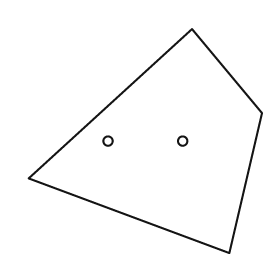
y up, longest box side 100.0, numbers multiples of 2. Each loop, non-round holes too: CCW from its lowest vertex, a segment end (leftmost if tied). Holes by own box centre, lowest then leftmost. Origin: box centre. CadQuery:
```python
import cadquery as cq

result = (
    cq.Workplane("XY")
    .moveTo(36.0, -48.0)
    .lineTo(50.0, 12.0)
    .lineTo(20.0, 48.0)
    .lineTo(-50.0, -16.0)
    .close()
    .moveTo(-16.0, 0.0)
    .circle(2.0)
    .moveTo(16.0, 0.0)
    .circle(2.0)
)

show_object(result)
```